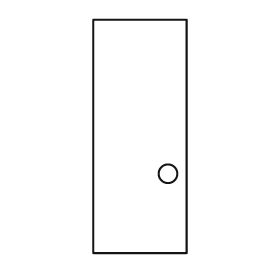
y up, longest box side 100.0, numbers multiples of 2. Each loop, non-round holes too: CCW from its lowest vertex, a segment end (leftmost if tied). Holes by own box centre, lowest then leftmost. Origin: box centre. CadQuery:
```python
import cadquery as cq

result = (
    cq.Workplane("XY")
    .moveTo(-20.0, -50.0)
    .lineTo(20.0, -50.0)
    .lineTo(20.0, 50.0)
    .lineTo(-20.0, 50.0)
    .close()
    .moveTo(12.0, -16.0)
    .circle(4.0)
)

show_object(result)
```